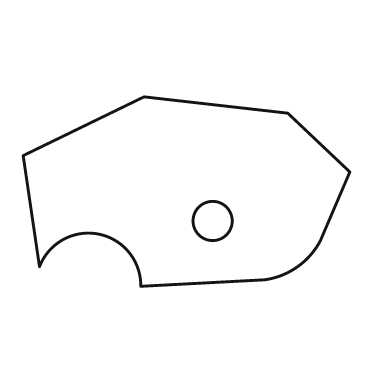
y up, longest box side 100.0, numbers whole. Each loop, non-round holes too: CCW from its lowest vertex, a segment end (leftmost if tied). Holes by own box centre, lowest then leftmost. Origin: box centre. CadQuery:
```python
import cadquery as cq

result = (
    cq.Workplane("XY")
    .moveTo(-14.0, -29.0)
    .lineTo(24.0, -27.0)
    .threePointArc((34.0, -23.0), (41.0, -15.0))
    .lineTo(50.0, 6.0)
    .lineTo(31.0, 24.0)
    .lineTo(-13.0, 29.0)
    .lineTo(-50.0, 11.0)
    .lineTo(-45.0, -23.0)
    .threePointArc((-27.0, -13.0), (-14.0, -29.0))
    .close()
    .moveTo(8.0, -9.0)
    .circle(6.0)
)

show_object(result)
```